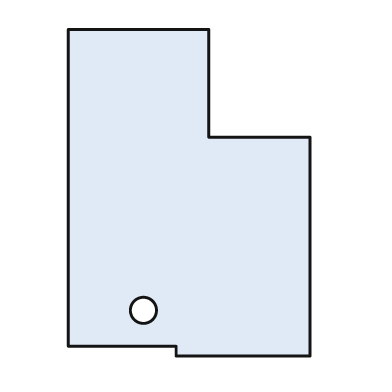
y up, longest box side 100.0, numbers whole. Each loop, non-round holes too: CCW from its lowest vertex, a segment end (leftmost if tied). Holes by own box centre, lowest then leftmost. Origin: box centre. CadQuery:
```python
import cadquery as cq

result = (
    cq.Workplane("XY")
    .moveTo(-4.0, -50.0)
    .lineTo(37.0, -50.0)
    .lineTo(37.0, 17.0)
    .lineTo(6.0, 17.0)
    .lineTo(6.0, 50.0)
    .lineTo(-37.0, 50.0)
    .lineTo(-37.0, -47.0)
    .lineTo(-4.0, -47.0)
    .close()
    .moveTo(-14.0, -36.0)
    .circle(4.0)
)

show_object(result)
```